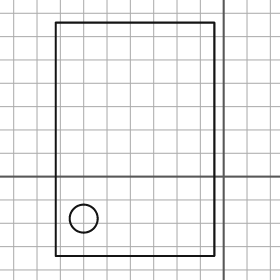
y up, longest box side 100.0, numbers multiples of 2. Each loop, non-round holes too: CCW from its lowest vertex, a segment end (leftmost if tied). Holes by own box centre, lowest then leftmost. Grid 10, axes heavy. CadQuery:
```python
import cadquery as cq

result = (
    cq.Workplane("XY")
    .moveTo(-72.0, -34.0)
    .lineTo(-4.0, -34.0)
    .lineTo(-4.0, 66.0)
    .lineTo(-72.0, 66.0)
    .close()
    .moveTo(-60.0, -18.0)
    .circle(6.0)
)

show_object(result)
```